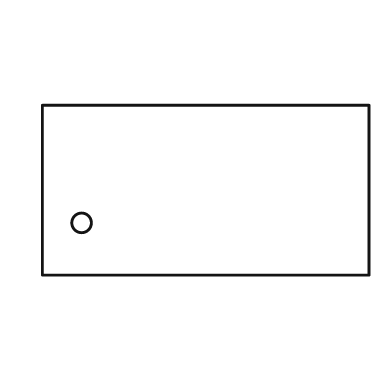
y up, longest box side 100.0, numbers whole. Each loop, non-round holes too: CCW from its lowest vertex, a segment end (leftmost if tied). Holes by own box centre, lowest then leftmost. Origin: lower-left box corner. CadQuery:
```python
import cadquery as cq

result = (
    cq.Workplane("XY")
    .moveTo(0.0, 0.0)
    .lineTo(100.0, 0.0)
    .lineTo(100.0, 52.0)
    .lineTo(0.0, 52.0)
    .close()
    .moveTo(12.0, 16.0)
    .circle(3.0)
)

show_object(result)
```